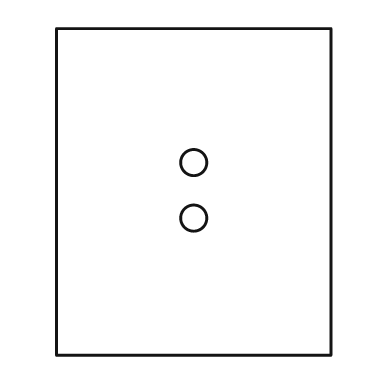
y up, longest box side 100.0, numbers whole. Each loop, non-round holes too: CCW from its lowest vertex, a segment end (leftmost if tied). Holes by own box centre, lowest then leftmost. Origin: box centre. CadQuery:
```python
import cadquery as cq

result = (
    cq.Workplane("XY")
    .moveTo(-42.0, -50.0)
    .lineTo(42.0, -50.0)
    .lineTo(42.0, 50.0)
    .lineTo(-42.0, 50.0)
    .close()
    .moveTo(0.0, -8.0)
    .circle(4.0)
    .moveTo(0.0, 9.0)
    .circle(4.0)
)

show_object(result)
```